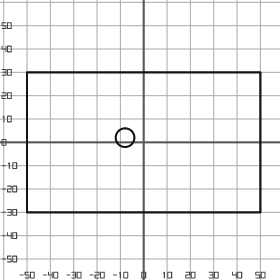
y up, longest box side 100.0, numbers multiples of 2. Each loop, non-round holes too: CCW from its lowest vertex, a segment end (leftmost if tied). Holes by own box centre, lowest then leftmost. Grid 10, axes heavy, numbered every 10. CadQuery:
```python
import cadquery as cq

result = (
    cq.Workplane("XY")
    .moveTo(-50.0, -30.0)
    .lineTo(50.0, -30.0)
    .lineTo(50.0, 30.0)
    .lineTo(-50.0, 30.0)
    .close()
    .moveTo(-8.0, 2.0)
    .circle(4.0)
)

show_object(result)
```